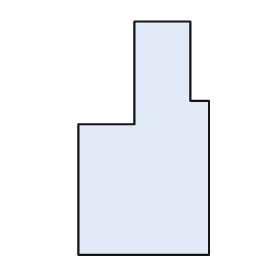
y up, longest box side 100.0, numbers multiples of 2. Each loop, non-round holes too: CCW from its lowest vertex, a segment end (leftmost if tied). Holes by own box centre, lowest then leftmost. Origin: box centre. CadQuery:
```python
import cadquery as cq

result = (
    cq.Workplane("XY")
    .moveTo(-28.0, -50.0)
    .lineTo(28.0, -50.0)
    .lineTo(28.0, 16.0)
    .lineTo(20.0, 16.0)
    .lineTo(20.0, 50.0)
    .lineTo(-4.0, 50.0)
    .lineTo(-4.0, 6.0)
    .lineTo(-28.0, 6.0)
    .close()
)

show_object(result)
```